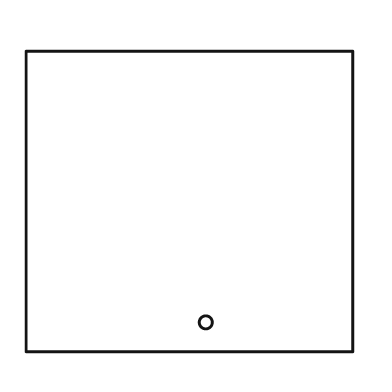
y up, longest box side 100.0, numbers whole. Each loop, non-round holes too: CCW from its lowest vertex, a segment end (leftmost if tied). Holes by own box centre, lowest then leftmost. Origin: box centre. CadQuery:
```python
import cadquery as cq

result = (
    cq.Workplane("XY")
    .moveTo(-50.0, -46.0)
    .lineTo(50.0, -46.0)
    .lineTo(50.0, 46.0)
    .lineTo(-50.0, 46.0)
    .close()
    .moveTo(5.0, -37.0)
    .circle(2.0)
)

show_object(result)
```